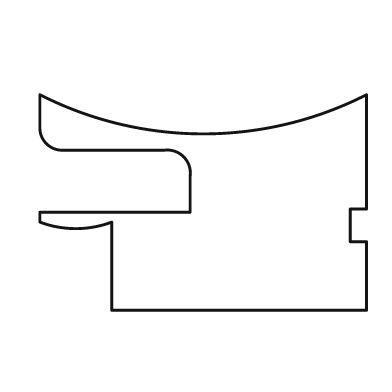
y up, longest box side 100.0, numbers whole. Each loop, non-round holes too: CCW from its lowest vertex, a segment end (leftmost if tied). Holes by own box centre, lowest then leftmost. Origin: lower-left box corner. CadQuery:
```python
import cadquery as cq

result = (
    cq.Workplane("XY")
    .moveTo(22.0, 0.0)
    .lineTo(100.0, 0.0)
    .lineTo(100.0, 21.0)
    .lineTo(95.0, 21.0)
    .lineTo(95.0, 31.0)
    .lineTo(100.0, 31.0)
    .lineTo(100.0, 66.0)
    .threePointArc((50.0, 54.0), (0.0, 66.0))
    .lineTo(0.0, 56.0)
    .threePointArc((2.0, 51.0), (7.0, 49.0))
    .lineTo(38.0, 49.0)
    .threePointArc((44.0, 47.0), (46.0, 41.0))
    .lineTo(46.0, 30.0)
    .lineTo(0.0, 30.0)
    .lineTo(0.0, 27.0)
    .threePointArc((11.0, 25.0), (22.0, 27.0))
    .close()
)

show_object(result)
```